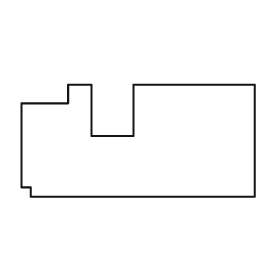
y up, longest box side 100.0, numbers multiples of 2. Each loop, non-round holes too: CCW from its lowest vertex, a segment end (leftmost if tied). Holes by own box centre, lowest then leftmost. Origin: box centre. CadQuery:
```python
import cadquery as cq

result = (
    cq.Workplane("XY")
    .moveTo(-46.0, -24.0)
    .lineTo(50.0, -24.0)
    .lineTo(50.0, 24.0)
    .lineTo(-2.0, 24.0)
    .lineTo(-2.0, 2.0)
    .lineTo(-20.0, 2.0)
    .lineTo(-20.0, 24.0)
    .lineTo(-30.0, 24.0)
    .lineTo(-30.0, 16.0)
    .lineTo(-50.0, 16.0)
    .lineTo(-50.0, -20.0)
    .lineTo(-46.0, -20.0)
    .close()
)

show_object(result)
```